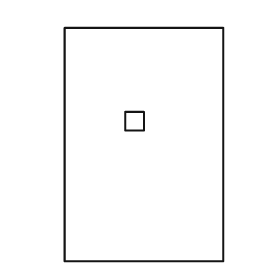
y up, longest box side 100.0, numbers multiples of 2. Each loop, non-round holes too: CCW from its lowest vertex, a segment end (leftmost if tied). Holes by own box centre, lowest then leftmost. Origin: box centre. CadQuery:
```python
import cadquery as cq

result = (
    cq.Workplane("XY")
    .moveTo(-34.0, -50.0)
    .lineTo(34.0, -50.0)
    .lineTo(34.0, 50.0)
    .lineTo(-34.0, 50.0)
    .close()
    .moveTo(-8.0, 6.0)
    .lineTo(0.0, 6.0)
    .lineTo(0.0, 14.0)
    .lineTo(-8.0, 14.0)
    .close()
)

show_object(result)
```